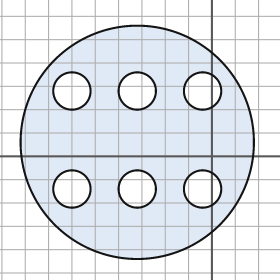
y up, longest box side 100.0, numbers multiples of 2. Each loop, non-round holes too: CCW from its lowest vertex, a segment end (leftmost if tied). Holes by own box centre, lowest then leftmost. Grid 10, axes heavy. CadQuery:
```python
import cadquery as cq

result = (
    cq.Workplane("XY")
    .moveTo(-32.0, 6.0)
    .circle(50.0)
    .moveTo(-60.0, -14.0)
    .circle(8.0)
    .moveTo(-32.0, -14.0)
    .circle(8.0)
    .moveTo(-4.0, -14.0)
    .circle(8.0)
    .moveTo(-60.0, 28.0)
    .circle(8.0)
    .moveTo(-32.0, 28.0)
    .circle(8.0)
    .moveTo(-4.0, 28.0)
    .circle(8.0)
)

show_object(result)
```